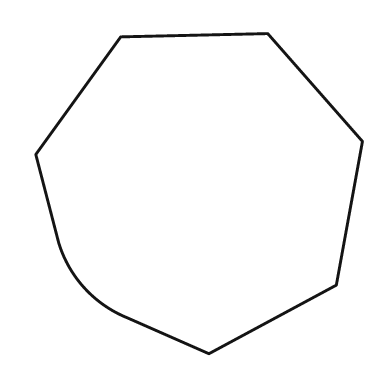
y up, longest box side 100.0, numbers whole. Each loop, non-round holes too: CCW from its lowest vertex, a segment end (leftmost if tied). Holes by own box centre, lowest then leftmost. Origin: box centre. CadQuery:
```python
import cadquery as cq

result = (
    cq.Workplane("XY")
    .moveTo(3.0, -49.0)
    .lineTo(42.0, -28.0)
    .lineTo(50.0, 16.0)
    .lineTo(21.0, 49.0)
    .lineTo(-24.0, 48.0)
    .lineTo(-50.0, 12.0)
    .lineTo(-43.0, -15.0)
    .threePointArc((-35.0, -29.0), (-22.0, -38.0))
    .close()
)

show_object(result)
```